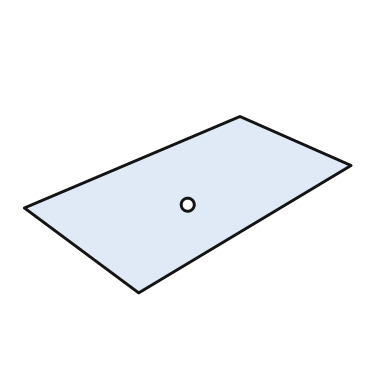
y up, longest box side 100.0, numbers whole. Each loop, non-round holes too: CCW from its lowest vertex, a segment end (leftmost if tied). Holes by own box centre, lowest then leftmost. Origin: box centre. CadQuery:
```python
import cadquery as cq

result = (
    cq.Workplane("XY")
    .moveTo(-15.0, -27.0)
    .lineTo(50.0, 12.0)
    .lineTo(16.0, 27.0)
    .lineTo(-50.0, -1.0)
    .close()
    .moveTo(0.0, 0.0)
    .circle(2.0)
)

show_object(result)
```